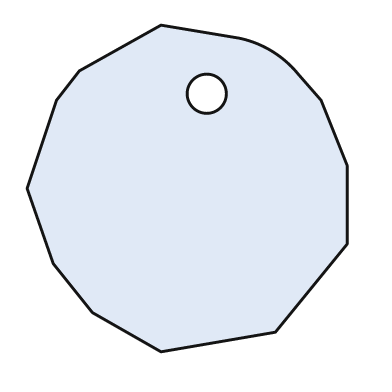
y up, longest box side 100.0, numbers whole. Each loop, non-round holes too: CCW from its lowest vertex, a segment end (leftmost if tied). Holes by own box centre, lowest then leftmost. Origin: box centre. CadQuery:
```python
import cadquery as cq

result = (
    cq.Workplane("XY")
    .moveTo(-8.0, -50.0)
    .lineTo(27.0, -44.0)
    .lineTo(49.0, -17.0)
    .lineTo(49.0, 7.0)
    .lineTo(41.0, 27.0)
    .lineTo(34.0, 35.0)
    .threePointArc((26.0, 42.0), (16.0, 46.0))
    .lineTo(-8.0, 50.0)
    .lineTo(-33.0, 36.0)
    .lineTo(-40.0, 27.0)
    .lineTo(-49.0, 0.0)
    .lineTo(-41.0, -23.0)
    .lineTo(-29.0, -38.0)
    .close()
    .moveTo(6.0, 29.0)
    .circle(6.0)
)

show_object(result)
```